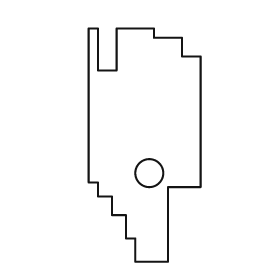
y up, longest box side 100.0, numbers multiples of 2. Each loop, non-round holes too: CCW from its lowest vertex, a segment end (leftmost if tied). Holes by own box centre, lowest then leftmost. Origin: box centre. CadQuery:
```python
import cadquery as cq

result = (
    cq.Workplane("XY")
    .moveTo(-4.0, -50.0)
    .lineTo(10.0, -50.0)
    .lineTo(10.0, -18.0)
    .lineTo(24.0, -18.0)
    .lineTo(24.0, 38.0)
    .lineTo(16.0, 38.0)
    .lineTo(16.0, 46.0)
    .lineTo(4.0, 46.0)
    .lineTo(4.0, 50.0)
    .lineTo(-12.0, 50.0)
    .lineTo(-12.0, 32.0)
    .lineTo(-20.0, 32.0)
    .lineTo(-20.0, 50.0)
    .lineTo(-24.0, 50.0)
    .lineTo(-24.0, -16.0)
    .lineTo(-20.0, -16.0)
    .lineTo(-20.0, -22.0)
    .lineTo(-14.0, -22.0)
    .lineTo(-14.0, -30.0)
    .lineTo(-8.0, -30.0)
    .lineTo(-8.0, -40.0)
    .lineTo(-4.0, -40.0)
    .close()
    .moveTo(2.0, -12.0)
    .circle(6.0)
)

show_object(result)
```